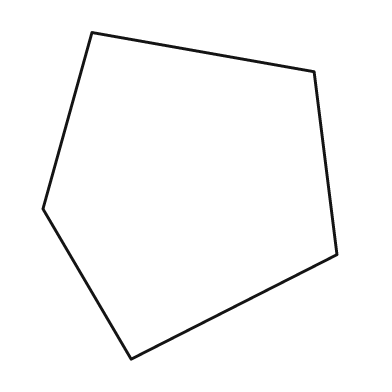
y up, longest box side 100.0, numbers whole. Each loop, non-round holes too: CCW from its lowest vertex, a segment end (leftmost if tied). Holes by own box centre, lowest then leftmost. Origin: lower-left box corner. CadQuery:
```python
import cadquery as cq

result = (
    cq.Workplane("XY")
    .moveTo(27.0, 0.0)
    .lineTo(90.0, 32.0)
    .lineTo(83.0, 88.0)
    .lineTo(15.0, 100.0)
    .lineTo(0.0, 46.0)
    .close()
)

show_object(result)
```